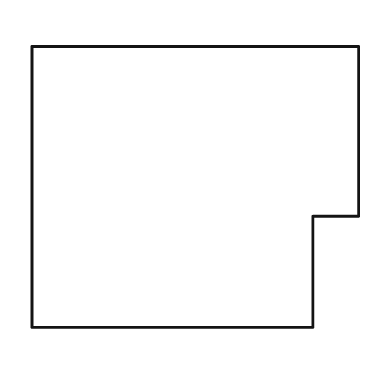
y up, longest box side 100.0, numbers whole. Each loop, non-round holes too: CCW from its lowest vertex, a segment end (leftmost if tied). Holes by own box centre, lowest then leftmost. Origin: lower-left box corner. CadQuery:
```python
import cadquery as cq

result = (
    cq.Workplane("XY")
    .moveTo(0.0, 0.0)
    .lineTo(86.0, 0.0)
    .lineTo(86.0, 34.0)
    .lineTo(100.0, 34.0)
    .lineTo(100.0, 86.0)
    .lineTo(0.0, 86.0)
    .close()
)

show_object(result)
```